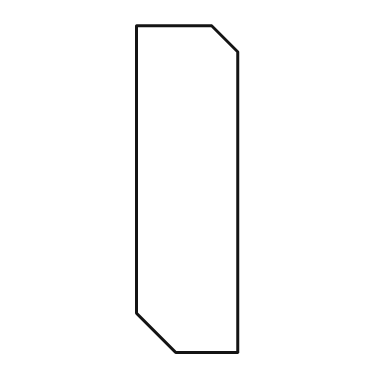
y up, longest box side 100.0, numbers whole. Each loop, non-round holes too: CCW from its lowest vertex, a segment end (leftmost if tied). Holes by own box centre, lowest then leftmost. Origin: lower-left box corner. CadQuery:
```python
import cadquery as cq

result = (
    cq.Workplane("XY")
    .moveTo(12.0, 0.0)
    .lineTo(31.0, 0.0)
    .lineTo(31.0, 92.0)
    .lineTo(23.0, 100.0)
    .lineTo(0.0, 100.0)
    .lineTo(0.0, 12.0)
    .close()
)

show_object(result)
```